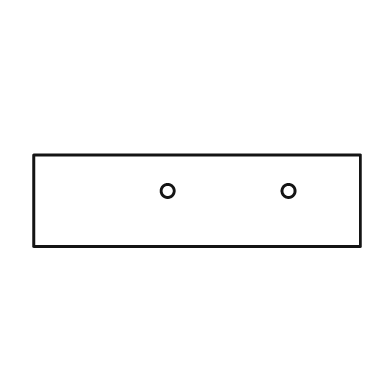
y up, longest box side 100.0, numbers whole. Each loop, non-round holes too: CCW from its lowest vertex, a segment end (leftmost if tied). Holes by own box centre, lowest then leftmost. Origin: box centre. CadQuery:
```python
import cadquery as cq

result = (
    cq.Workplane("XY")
    .moveTo(-50.0, -14.0)
    .lineTo(50.0, -14.0)
    .lineTo(50.0, 14.0)
    .lineTo(-50.0, 14.0)
    .close()
    .moveTo(-9.0, 3.0)
    .circle(2.0)
    .moveTo(28.0, 3.0)
    .circle(2.0)
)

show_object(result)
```